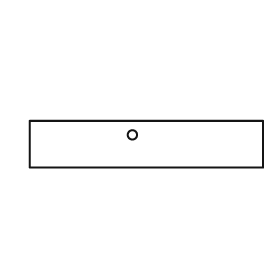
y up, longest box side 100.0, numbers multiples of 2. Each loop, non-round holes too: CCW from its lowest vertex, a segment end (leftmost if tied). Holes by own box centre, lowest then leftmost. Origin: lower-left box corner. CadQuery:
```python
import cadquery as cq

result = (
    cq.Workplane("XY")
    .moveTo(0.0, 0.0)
    .lineTo(100.0, 0.0)
    .lineTo(100.0, 20.0)
    .lineTo(0.0, 20.0)
    .close()
    .moveTo(44.0, 14.0)
    .circle(2.0)
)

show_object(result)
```